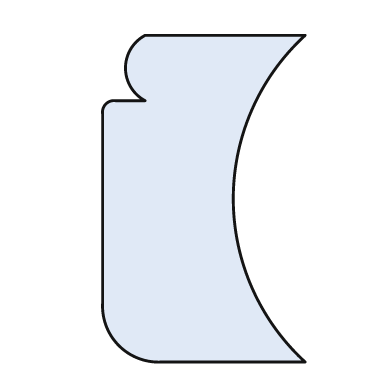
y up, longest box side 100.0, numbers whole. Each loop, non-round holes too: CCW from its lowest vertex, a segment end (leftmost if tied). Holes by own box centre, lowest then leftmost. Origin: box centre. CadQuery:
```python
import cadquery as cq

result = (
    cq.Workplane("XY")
    .moveTo(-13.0, -50.0)
    .lineTo(31.0, -50.0)
    .threePointArc((9.0, 0.0), (31.0, 50.0))
    .lineTo(-18.0, 50.0)
    .threePointArc((-24.0, 40.0), (-18.0, 30.0))
    .lineTo(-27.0, 30.0)
    .threePointArc((-30.0, 29.0), (-31.0, 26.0))
    .lineTo(-31.0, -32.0)
    .threePointArc((-26.0, -45.0), (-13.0, -50.0))
    .close()
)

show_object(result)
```